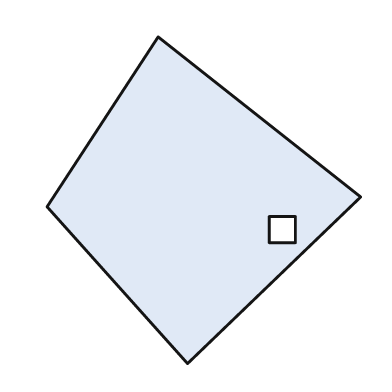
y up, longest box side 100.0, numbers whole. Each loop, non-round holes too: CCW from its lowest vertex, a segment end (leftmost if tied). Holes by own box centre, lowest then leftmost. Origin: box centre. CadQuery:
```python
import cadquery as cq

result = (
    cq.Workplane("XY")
    .moveTo(-5.0, -50.0)
    .lineTo(48.0, 1.0)
    .lineTo(-14.0, 50.0)
    .lineTo(-48.0, -2.0)
    .close()
    .moveTo(20.0, -13.0)
    .lineTo(28.0, -13.0)
    .lineTo(28.0, -5.0)
    .lineTo(20.0, -5.0)
    .close()
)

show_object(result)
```